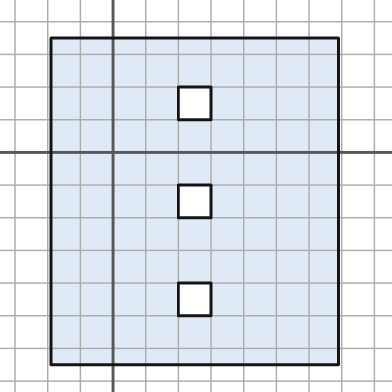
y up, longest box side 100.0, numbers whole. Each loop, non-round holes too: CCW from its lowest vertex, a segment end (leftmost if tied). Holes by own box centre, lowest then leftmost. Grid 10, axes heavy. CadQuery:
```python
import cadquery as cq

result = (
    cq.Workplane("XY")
    .moveTo(-19.0, -65.0)
    .lineTo(69.0, -65.0)
    .lineTo(69.0, 35.0)
    .lineTo(-19.0, 35.0)
    .close()
    .moveTo(20.0, -50.0)
    .lineTo(30.0, -50.0)
    .lineTo(30.0, -40.0)
    .lineTo(20.0, -40.0)
    .close()
    .moveTo(20.0, -20.0)
    .lineTo(30.0, -20.0)
    .lineTo(30.0, -10.0)
    .lineTo(20.0, -10.0)
    .close()
    .moveTo(20.0, 10.0)
    .lineTo(30.0, 10.0)
    .lineTo(30.0, 20.0)
    .lineTo(20.0, 20.0)
    .close()
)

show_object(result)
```